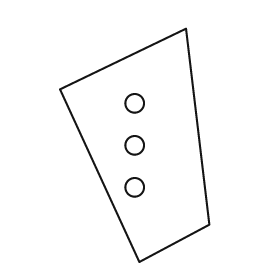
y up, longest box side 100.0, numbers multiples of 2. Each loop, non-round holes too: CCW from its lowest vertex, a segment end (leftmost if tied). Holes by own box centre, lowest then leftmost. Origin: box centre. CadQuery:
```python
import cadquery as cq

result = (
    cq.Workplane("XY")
    .moveTo(2.0, -50.0)
    .lineTo(32.0, -34.0)
    .lineTo(22.0, 50.0)
    .lineTo(-32.0, 24.0)
    .close()
    .moveTo(0.0, -18.0)
    .circle(4.0)
    .moveTo(0.0, 0.0)
    .circle(4.0)
    .moveTo(0.0, 18.0)
    .circle(4.0)
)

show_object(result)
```